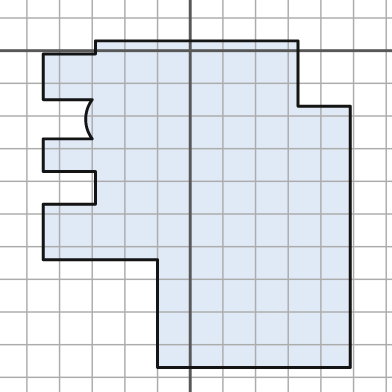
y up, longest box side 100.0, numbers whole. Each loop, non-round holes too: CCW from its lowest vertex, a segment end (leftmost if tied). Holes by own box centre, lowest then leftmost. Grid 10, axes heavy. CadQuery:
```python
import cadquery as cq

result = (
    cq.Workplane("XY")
    .moveTo(-10.0, -97.0)
    .lineTo(49.0, -97.0)
    .lineTo(49.0, -17.0)
    .lineTo(33.0, -17.0)
    .lineTo(33.0, 3.0)
    .lineTo(-29.0, 3.0)
    .lineTo(-29.0, -1.0)
    .lineTo(-45.0, -1.0)
    .lineTo(-45.0, -15.0)
    .lineTo(-30.0, -15.0)
    .threePointArc((-32.0, -21.0), (-30.0, -27.0))
    .lineTo(-45.0, -27.0)
    .lineTo(-45.0, -37.0)
    .lineTo(-29.0, -37.0)
    .lineTo(-29.0, -47.0)
    .lineTo(-45.0, -47.0)
    .lineTo(-45.0, -64.0)
    .lineTo(-10.0, -64.0)
    .close()
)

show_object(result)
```